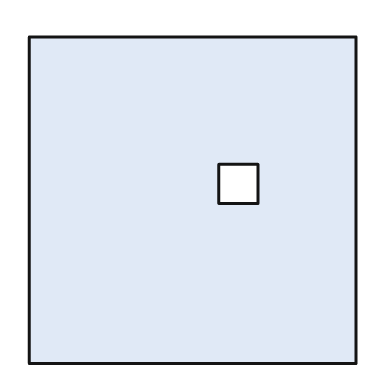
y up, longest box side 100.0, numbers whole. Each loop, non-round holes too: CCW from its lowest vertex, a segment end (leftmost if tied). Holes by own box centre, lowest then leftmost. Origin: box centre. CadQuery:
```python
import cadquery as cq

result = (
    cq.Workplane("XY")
    .moveTo(-50.0, -50.0)
    .lineTo(50.0, -50.0)
    .lineTo(50.0, 50.0)
    .lineTo(-50.0, 50.0)
    .close()
    .moveTo(8.0, -1.0)
    .lineTo(20.0, -1.0)
    .lineTo(20.0, 11.0)
    .lineTo(8.0, 11.0)
    .close()
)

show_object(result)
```